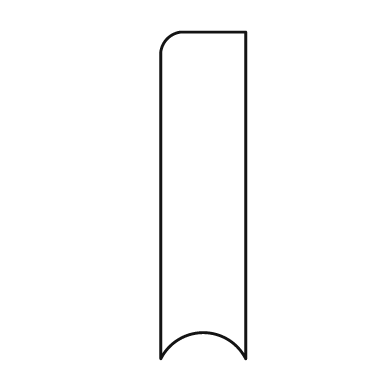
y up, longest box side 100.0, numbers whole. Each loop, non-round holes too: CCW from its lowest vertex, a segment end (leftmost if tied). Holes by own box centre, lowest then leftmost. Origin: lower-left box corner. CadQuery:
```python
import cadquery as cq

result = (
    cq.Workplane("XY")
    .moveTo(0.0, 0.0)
    .threePointArc((13.0, 8.0), (26.0, 0.0))
    .lineTo(26.0, 100.0)
    .lineTo(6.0, 100.0)
    .threePointArc((2.0, 98.0), (0.0, 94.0))
    .close()
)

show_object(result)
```